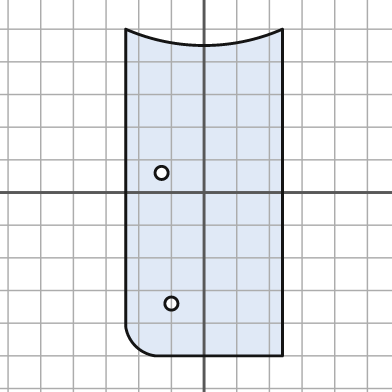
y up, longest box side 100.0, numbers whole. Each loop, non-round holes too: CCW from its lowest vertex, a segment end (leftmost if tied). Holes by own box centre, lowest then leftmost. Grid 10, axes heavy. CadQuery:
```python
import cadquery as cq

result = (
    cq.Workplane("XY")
    .moveTo(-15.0, -50.0)
    .lineTo(24.0, -50.0)
    .lineTo(24.0, 50.0)
    .threePointArc((0.0, 45.0), (-24.0, 50.0))
    .lineTo(-24.0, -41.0)
    .threePointArc((-21.0, -47.0), (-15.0, -50.0))
    .close()
    .moveTo(-10.0, -34.0)
    .circle(2.0)
    .moveTo(-13.0, 6.0)
    .circle(2.0)
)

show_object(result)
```